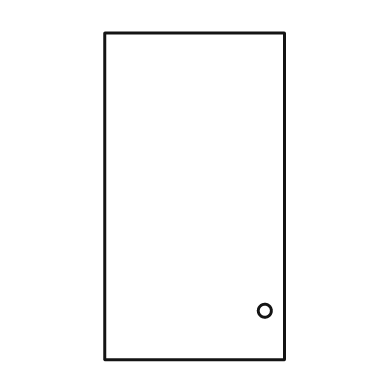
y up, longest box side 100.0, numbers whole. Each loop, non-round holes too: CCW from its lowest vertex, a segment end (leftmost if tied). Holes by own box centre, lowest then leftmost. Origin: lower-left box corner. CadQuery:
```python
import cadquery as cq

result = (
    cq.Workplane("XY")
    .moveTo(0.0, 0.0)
    .lineTo(55.0, 0.0)
    .lineTo(55.0, 100.0)
    .lineTo(0.0, 100.0)
    .close()
    .moveTo(49.0, 15.0)
    .circle(2.0)
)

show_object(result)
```